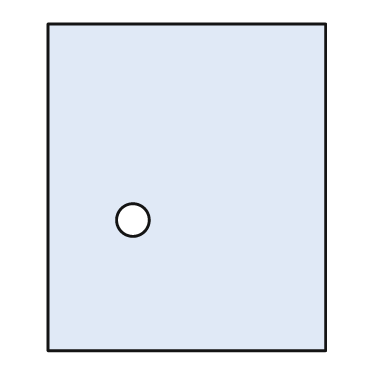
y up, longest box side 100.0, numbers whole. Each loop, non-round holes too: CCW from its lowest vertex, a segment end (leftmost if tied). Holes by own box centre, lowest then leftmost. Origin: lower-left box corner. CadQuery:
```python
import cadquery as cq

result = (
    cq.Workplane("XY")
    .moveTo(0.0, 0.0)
    .lineTo(85.0, 0.0)
    .lineTo(85.0, 100.0)
    .lineTo(0.0, 100.0)
    .close()
    .moveTo(26.0, 40.0)
    .circle(5.0)
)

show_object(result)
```